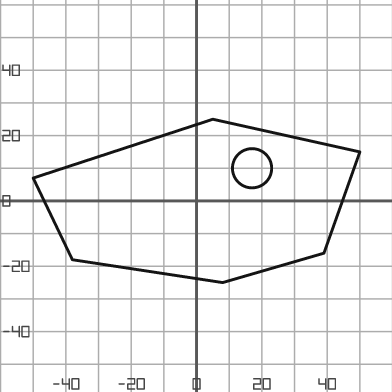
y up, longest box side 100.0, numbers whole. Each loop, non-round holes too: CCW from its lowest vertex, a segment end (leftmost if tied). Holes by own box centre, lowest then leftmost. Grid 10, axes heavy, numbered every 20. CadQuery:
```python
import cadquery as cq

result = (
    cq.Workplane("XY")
    .moveTo(8.0, -25.0)
    .lineTo(39.0, -16.0)
    .lineTo(50.0, 15.0)
    .lineTo(5.0, 25.0)
    .lineTo(-50.0, 7.0)
    .lineTo(-38.0, -18.0)
    .close()
    .moveTo(17.0, 10.0)
    .circle(6.0)
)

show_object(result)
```